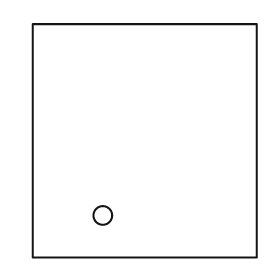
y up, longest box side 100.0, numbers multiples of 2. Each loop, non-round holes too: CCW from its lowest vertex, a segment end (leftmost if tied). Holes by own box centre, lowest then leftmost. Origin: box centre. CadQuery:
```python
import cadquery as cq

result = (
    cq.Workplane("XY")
    .moveTo(-48.0, -50.0)
    .lineTo(48.0, -50.0)
    .lineTo(48.0, 50.0)
    .lineTo(-48.0, 50.0)
    .close()
    .moveTo(-18.0, -32.0)
    .circle(4.0)
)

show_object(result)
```